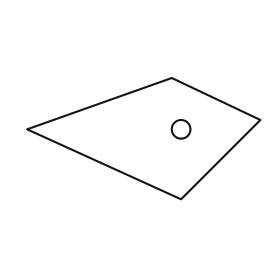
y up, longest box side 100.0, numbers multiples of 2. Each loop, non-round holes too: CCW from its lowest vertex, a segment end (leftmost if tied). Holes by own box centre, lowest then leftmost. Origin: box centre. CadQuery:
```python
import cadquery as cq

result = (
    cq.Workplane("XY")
    .moveTo(16.0, -26.0)
    .lineTo(50.0, 8.0)
    .lineTo(12.0, 26.0)
    .lineTo(-50.0, 4.0)
    .close()
    .moveTo(16.0, 4.0)
    .circle(4.0)
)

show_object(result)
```